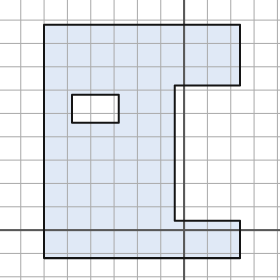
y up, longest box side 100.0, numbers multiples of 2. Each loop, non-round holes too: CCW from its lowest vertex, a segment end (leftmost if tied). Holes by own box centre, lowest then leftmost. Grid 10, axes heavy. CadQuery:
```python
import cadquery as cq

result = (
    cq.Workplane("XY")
    .moveTo(-60.0, -12.0)
    .lineTo(24.0, -12.0)
    .lineTo(24.0, 4.0)
    .lineTo(-4.0, 4.0)
    .lineTo(-4.0, 62.0)
    .lineTo(24.0, 62.0)
    .lineTo(24.0, 88.0)
    .lineTo(-60.0, 88.0)
    .close()
    .moveTo(-48.0, 46.0)
    .lineTo(-28.0, 46.0)
    .lineTo(-28.0, 58.0)
    .lineTo(-48.0, 58.0)
    .close()
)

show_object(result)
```